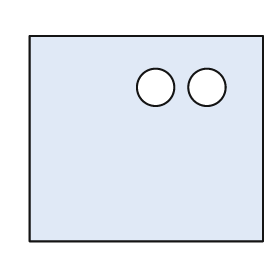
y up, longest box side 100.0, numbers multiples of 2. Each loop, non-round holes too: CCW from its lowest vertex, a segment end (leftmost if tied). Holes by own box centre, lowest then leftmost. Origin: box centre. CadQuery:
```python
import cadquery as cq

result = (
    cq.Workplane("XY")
    .moveTo(-50.0, -44.0)
    .lineTo(50.0, -44.0)
    .lineTo(50.0, 44.0)
    .lineTo(-50.0, 44.0)
    .close()
    .moveTo(4.0, 22.0)
    .circle(8.0)
    .moveTo(26.0, 22.0)
    .circle(8.0)
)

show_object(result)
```